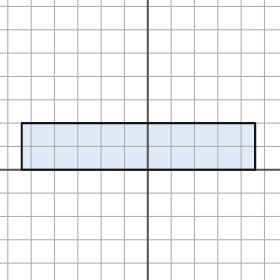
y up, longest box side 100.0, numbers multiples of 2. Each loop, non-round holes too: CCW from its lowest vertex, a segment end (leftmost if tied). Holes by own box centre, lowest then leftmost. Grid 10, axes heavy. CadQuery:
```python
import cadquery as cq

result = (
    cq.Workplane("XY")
    .moveTo(-54.0, 0.0)
    .lineTo(46.0, 0.0)
    .lineTo(46.0, 20.0)
    .lineTo(-54.0, 20.0)
    .close()
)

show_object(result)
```